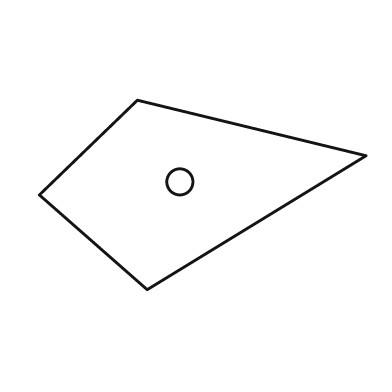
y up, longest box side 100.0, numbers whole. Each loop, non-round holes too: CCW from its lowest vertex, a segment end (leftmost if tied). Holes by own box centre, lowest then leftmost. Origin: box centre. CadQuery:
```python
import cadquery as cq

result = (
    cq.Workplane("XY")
    .moveTo(-17.0, -29.0)
    .lineTo(50.0, 12.0)
    .lineTo(-20.0, 29.0)
    .lineTo(-50.0, 0.0)
    .close()
    .moveTo(-7.0, 4.0)
    .circle(4.0)
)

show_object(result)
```